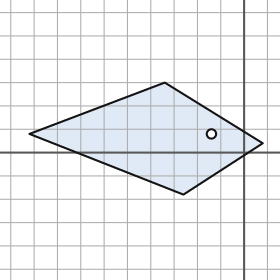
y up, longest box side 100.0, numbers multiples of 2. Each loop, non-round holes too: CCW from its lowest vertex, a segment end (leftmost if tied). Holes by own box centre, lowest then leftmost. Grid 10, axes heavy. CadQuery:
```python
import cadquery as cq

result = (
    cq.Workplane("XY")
    .moveTo(-26.0, -18.0)
    .lineTo(8.0, 4.0)
    .lineTo(-34.0, 30.0)
    .lineTo(-92.0, 8.0)
    .close()
    .moveTo(-14.0, 8.0)
    .circle(2.0)
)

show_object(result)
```